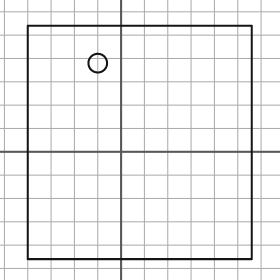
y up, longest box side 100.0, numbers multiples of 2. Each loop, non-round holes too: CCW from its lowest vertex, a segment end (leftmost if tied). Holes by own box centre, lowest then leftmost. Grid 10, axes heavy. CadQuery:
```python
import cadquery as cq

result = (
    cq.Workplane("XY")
    .moveTo(-40.0, -46.0)
    .lineTo(56.0, -46.0)
    .lineTo(56.0, 54.0)
    .lineTo(-40.0, 54.0)
    .close()
    .moveTo(-10.0, 38.0)
    .circle(4.0)
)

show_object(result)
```